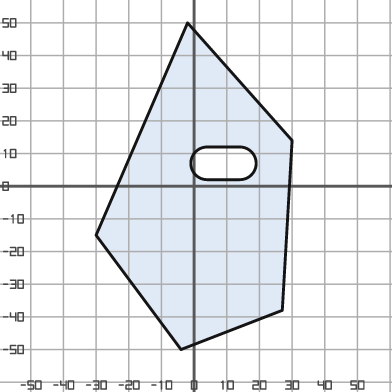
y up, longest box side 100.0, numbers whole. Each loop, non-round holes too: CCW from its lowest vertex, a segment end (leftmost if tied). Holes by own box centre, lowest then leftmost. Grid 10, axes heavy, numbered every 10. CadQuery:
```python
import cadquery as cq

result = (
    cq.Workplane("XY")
    .moveTo(-4.0, -50.0)
    .lineTo(27.0, -38.0)
    .lineTo(30.0, 14.0)
    .lineTo(-2.0, 50.0)
    .lineTo(-30.0, -15.0)
    .close()
    .moveTo(4.0, 2.0)
    .lineTo(14.0, 2.0)
    .threePointArc((19.0, 7.0), (14.0, 12.0))
    .lineTo(4.0, 12.0)
    .threePointArc((-1.0, 7.0), (4.0, 2.0))
    .close()
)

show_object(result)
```